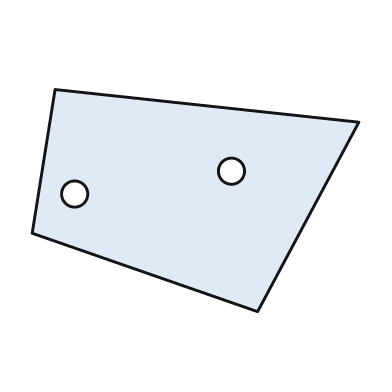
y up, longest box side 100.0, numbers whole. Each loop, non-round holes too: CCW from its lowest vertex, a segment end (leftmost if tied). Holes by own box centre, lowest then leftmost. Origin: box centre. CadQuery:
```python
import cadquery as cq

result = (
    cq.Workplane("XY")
    .moveTo(19.0, -34.0)
    .lineTo(50.0, 24.0)
    .lineTo(-43.0, 34.0)
    .lineTo(-50.0, -10.0)
    .close()
    .moveTo(-37.0, 2.0)
    .circle(4.0)
    .moveTo(11.0, 9.0)
    .circle(4.0)
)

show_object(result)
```